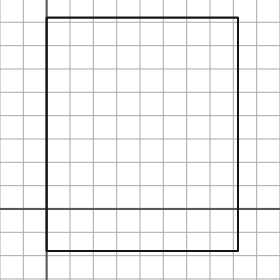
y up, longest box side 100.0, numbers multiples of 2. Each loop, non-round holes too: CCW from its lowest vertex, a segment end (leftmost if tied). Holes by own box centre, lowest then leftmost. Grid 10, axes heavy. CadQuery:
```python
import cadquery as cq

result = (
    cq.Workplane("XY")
    .moveTo(0.0, -18.0)
    .lineTo(82.0, -18.0)
    .lineTo(82.0, 82.0)
    .lineTo(0.0, 82.0)
    .close()
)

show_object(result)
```